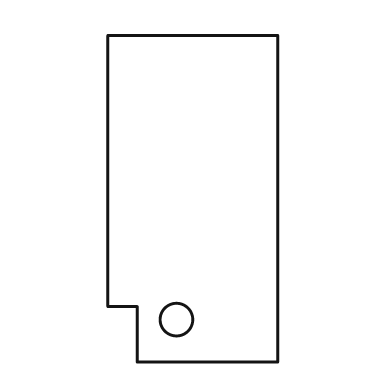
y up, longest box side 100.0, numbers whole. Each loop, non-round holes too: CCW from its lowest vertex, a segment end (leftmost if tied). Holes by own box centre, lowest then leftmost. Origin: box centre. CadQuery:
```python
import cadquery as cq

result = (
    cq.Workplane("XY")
    .moveTo(-17.0, -50.0)
    .lineTo(26.0, -50.0)
    .lineTo(26.0, 50.0)
    .lineTo(-26.0, 50.0)
    .lineTo(-26.0, -33.0)
    .lineTo(-17.0, -33.0)
    .close()
    .moveTo(-5.0, -37.0)
    .circle(5.0)
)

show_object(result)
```